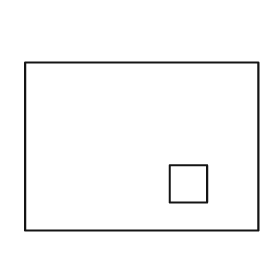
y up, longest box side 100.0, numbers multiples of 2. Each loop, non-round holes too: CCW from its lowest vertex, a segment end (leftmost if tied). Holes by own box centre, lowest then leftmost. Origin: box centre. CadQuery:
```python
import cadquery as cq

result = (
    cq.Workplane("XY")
    .moveTo(-50.0, -36.0)
    .lineTo(50.0, -36.0)
    .lineTo(50.0, 36.0)
    .lineTo(-50.0, 36.0)
    .close()
    .moveTo(12.0, -24.0)
    .lineTo(28.0, -24.0)
    .lineTo(28.0, -8.0)
    .lineTo(12.0, -8.0)
    .close()
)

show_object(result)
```